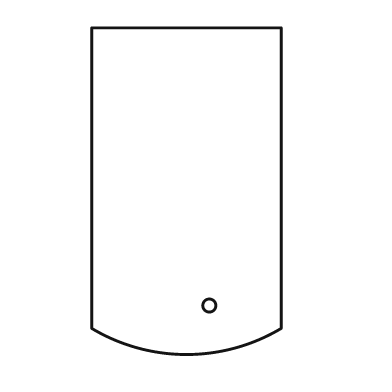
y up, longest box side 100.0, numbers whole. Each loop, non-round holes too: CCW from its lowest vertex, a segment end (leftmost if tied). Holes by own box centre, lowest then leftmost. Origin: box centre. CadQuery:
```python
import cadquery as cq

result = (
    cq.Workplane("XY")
    .moveTo(-29.0, -42.0)
    .threePointArc((0.0, -50.0), (29.0, -42.0))
    .lineTo(29.0, 50.0)
    .lineTo(-29.0, 50.0)
    .close()
    .moveTo(7.0, -35.0)
    .circle(2.0)
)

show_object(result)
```